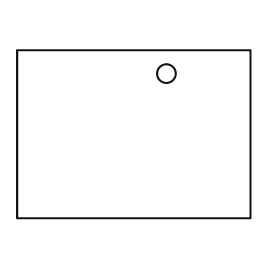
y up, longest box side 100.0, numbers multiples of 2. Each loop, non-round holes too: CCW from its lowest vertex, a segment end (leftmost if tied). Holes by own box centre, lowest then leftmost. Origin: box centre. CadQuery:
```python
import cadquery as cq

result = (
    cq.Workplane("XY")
    .moveTo(-50.0, -36.0)
    .lineTo(50.0, -36.0)
    .lineTo(50.0, 36.0)
    .lineTo(-50.0, 36.0)
    .close()
    .moveTo(14.0, 26.0)
    .circle(4.0)
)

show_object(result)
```